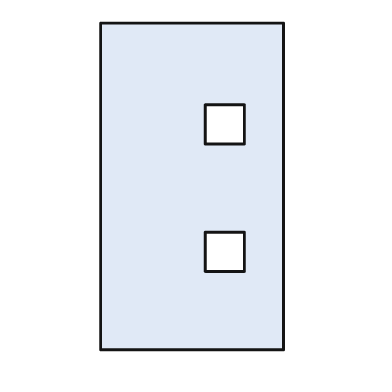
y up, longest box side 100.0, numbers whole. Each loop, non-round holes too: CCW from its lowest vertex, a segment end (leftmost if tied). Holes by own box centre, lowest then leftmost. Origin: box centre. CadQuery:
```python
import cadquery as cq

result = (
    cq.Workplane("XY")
    .moveTo(-28.0, -50.0)
    .lineTo(28.0, -50.0)
    .lineTo(28.0, 50.0)
    .lineTo(-28.0, 50.0)
    .close()
    .moveTo(4.0, -26.0)
    .lineTo(16.0, -26.0)
    .lineTo(16.0, -14.0)
    .lineTo(4.0, -14.0)
    .close()
    .moveTo(4.0, 13.0)
    .lineTo(16.0, 13.0)
    .lineTo(16.0, 25.0)
    .lineTo(4.0, 25.0)
    .close()
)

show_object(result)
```